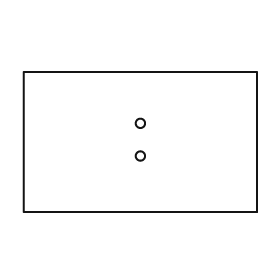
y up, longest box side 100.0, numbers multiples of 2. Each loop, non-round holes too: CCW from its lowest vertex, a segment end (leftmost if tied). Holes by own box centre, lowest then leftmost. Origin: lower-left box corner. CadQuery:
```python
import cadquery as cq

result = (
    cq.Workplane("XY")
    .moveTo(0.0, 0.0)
    .lineTo(100.0, 0.0)
    .lineTo(100.0, 60.0)
    .lineTo(0.0, 60.0)
    .close()
    .moveTo(50.0, 24.0)
    .circle(2.0)
    .moveTo(50.0, 38.0)
    .circle(2.0)
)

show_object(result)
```